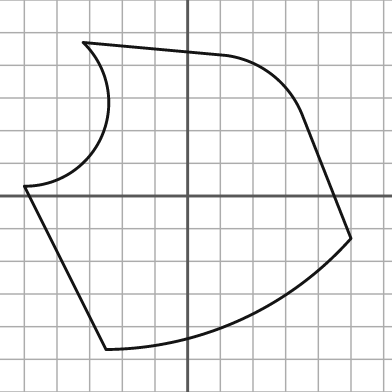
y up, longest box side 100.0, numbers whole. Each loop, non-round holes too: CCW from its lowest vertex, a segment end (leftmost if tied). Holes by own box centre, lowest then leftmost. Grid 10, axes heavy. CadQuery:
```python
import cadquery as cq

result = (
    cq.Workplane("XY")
    .moveTo(-25.0, -47.0)
    .threePointArc((16.0, -38.0), (50.0, -13.0))
    .lineTo(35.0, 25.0)
    .threePointArc((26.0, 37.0), (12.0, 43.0))
    .lineTo(-32.0, 47.0)
    .threePointArc((-26.0, 19.0), (-50.0, 3.0))
    .close()
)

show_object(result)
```